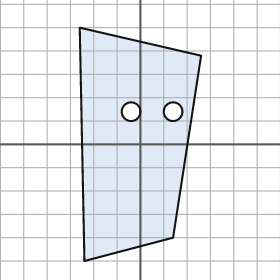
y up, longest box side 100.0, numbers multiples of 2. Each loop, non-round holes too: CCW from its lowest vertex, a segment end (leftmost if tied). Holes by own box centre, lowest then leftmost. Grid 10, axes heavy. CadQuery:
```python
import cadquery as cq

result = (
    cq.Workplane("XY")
    .moveTo(-24.0, -50.0)
    .lineTo(14.0, -40.0)
    .lineTo(26.0, 38.0)
    .lineTo(-26.0, 50.0)
    .close()
    .moveTo(-4.0, 14.0)
    .circle(4.0)
    .moveTo(14.0, 14.0)
    .circle(4.0)
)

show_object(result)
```